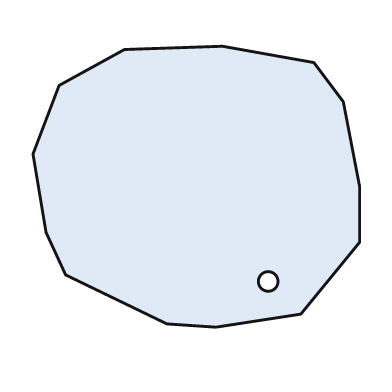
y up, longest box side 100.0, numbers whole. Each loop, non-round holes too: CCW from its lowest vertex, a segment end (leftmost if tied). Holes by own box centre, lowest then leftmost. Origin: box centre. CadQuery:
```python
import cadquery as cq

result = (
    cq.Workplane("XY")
    .moveTo(6.0, -43.0)
    .lineTo(32.0, -39.0)
    .lineTo(50.0, -17.0)
    .lineTo(50.0, 0.0)
    .lineTo(45.0, 26.0)
    .lineTo(36.0, 38.0)
    .lineTo(8.0, 43.0)
    .lineTo(-22.0, 42.0)
    .lineTo(-42.0, 31.0)
    .lineTo(-50.0, 10.0)
    .lineTo(-46.0, -14.0)
    .lineTo(-40.0, -27.0)
    .lineTo(-9.0, -42.0)
    .close()
    .moveTo(22.0, -29.0)
    .circle(3.0)
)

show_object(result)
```